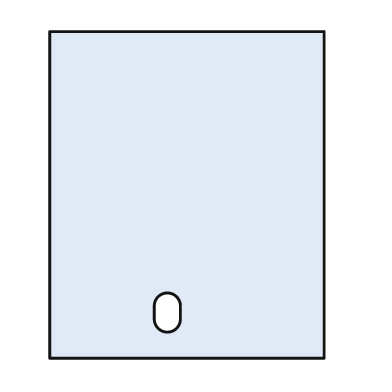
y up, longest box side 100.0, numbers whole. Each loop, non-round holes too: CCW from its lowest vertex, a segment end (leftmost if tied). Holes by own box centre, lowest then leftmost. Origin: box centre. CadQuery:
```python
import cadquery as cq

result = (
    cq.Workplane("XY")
    .moveTo(-42.0, -50.0)
    .lineTo(42.0, -50.0)
    .lineTo(42.0, 50.0)
    .lineTo(-42.0, 50.0)
    .close()
    .moveTo(-10.0, -38.0)
    .threePointArc((-6.0, -42.0), (-2.0, -38.0))
    .lineTo(-2.0, -34.0)
    .threePointArc((-6.0, -30.0), (-10.0, -34.0))
    .close()
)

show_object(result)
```